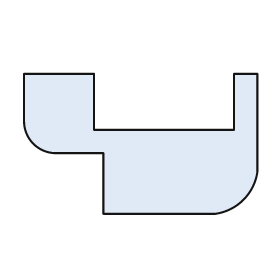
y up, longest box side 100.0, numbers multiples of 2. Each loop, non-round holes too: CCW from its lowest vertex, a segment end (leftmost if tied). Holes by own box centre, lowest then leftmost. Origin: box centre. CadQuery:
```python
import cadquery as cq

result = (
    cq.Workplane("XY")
    .moveTo(-16.0, -30.0)
    .lineTo(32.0, -30.0)
    .threePointArc((44.0, -24.0), (50.0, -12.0))
    .lineTo(50.0, 30.0)
    .lineTo(40.0, 30.0)
    .lineTo(40.0, 6.0)
    .lineTo(-20.0, 6.0)
    .lineTo(-20.0, 30.0)
    .lineTo(-50.0, 30.0)
    .lineTo(-50.0, 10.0)
    .threePointArc((-46.0, 0.0), (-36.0, -4.0))
    .lineTo(-16.0, -4.0)
    .close()
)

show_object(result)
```